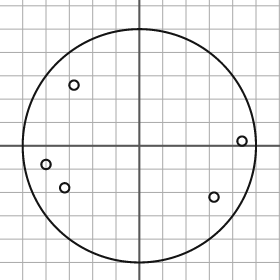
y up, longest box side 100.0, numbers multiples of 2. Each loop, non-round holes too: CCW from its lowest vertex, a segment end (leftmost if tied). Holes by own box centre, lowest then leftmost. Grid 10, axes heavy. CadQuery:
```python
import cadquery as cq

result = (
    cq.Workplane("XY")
    .moveTo(0.0, 0.0)
    .circle(50.0)
    .moveTo(32.0, -22.0)
    .circle(2.0)
    .moveTo(-32.0, -18.0)
    .circle(2.0)
    .moveTo(-40.0, -8.0)
    .circle(2.0)
    .moveTo(44.0, 2.0)
    .circle(2.0)
    .moveTo(-28.0, 26.0)
    .circle(2.0)
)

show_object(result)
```